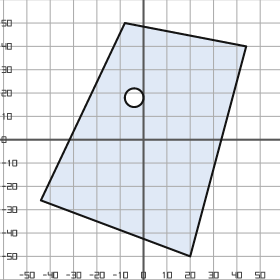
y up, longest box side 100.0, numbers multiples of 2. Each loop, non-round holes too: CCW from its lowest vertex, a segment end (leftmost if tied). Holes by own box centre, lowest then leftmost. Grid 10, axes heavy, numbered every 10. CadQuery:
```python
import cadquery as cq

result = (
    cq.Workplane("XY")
    .moveTo(20.0, -50.0)
    .lineTo(44.0, 40.0)
    .lineTo(-8.0, 50.0)
    .lineTo(-44.0, -26.0)
    .close()
    .moveTo(-4.0, 18.0)
    .circle(4.0)
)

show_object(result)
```